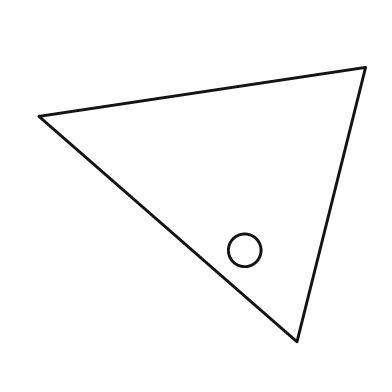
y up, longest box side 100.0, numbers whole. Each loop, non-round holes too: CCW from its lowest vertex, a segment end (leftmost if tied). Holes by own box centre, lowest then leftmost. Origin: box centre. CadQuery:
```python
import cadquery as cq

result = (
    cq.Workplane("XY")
    .moveTo(29.0, -42.0)
    .lineTo(50.0, 42.0)
    .lineTo(-50.0, 27.0)
    .close()
    .moveTo(13.0, -14.0)
    .circle(5.0)
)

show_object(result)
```